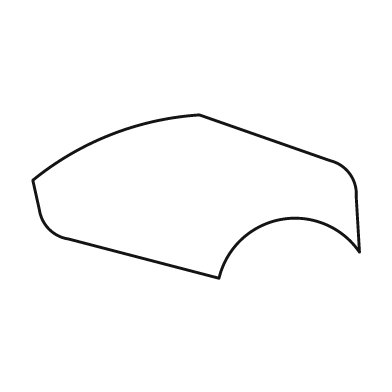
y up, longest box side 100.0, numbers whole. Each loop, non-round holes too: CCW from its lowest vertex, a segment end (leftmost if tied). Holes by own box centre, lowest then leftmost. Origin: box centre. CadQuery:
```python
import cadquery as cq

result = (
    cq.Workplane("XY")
    .moveTo(7.0, -25.0)
    .threePointArc((26.0, -7.0), (50.0, -17.0))
    .lineTo(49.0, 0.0)
    .threePointArc((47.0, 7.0), (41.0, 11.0))
    .lineTo(1.0, 25.0)
    .threePointArc((-26.0, 19.0), (-50.0, 5.0))
    .lineTo(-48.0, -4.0)
    .threePointArc((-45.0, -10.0), (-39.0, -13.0))
    .close()
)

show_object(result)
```